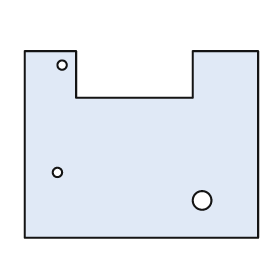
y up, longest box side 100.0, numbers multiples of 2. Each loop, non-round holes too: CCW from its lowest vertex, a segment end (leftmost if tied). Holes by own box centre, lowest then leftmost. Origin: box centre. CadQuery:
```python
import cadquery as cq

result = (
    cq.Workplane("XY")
    .moveTo(-50.0, -40.0)
    .lineTo(50.0, -40.0)
    .lineTo(50.0, 40.0)
    .lineTo(22.0, 40.0)
    .lineTo(22.0, 20.0)
    .lineTo(-28.0, 20.0)
    .lineTo(-28.0, 40.0)
    .lineTo(-50.0, 40.0)
    .close()
    .moveTo(26.0, -24.0)
    .circle(4.0)
    .moveTo(-36.0, -12.0)
    .circle(2.0)
    .moveTo(-34.0, 34.0)
    .circle(2.0)
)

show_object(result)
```